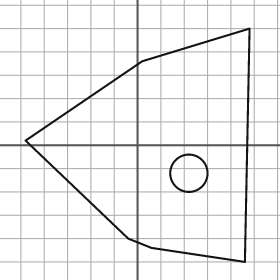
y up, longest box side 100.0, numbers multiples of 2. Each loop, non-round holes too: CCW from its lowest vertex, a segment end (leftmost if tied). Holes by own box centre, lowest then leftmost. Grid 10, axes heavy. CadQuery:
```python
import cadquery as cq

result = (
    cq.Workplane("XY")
    .moveTo(46.0, -50.0)
    .lineTo(48.0, 50.0)
    .lineTo(2.0, 36.0)
    .lineTo(-48.0, 2.0)
    .lineTo(-4.0, -40.0)
    .lineTo(6.0, -44.0)
    .close()
    .moveTo(22.0, -12.0)
    .circle(8.0)
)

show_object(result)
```